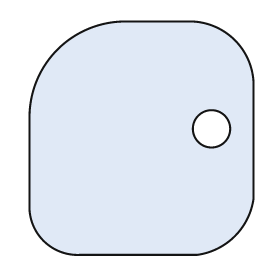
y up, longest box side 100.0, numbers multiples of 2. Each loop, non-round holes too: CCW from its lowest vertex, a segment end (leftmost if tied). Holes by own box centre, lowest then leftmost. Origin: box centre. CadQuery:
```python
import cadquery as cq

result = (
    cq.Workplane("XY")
    .moveTo(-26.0, -50.0)
    .lineTo(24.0, -50.0)
    .threePointArc((40.0, -42.0), (48.0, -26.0))
    .lineTo(48.0, 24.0)
    .threePointArc((40.0, 42.0), (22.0, 50.0))
    .lineTo(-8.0, 50.0)
    .threePointArc((-36.0, 38.0), (-48.0, 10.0))
    .lineTo(-48.0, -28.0)
    .threePointArc((-42.0, -44.0), (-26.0, -50.0))
    .close()
    .moveTo(30.0, 4.0)
    .circle(8.0)
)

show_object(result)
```